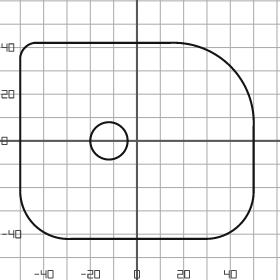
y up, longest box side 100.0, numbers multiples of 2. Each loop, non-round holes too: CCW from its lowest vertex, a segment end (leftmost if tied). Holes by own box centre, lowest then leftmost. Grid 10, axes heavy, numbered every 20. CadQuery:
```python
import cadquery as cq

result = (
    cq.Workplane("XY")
    .moveTo(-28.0, -42.0)
    .lineTo(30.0, -42.0)
    .threePointArc((44.0, -36.0), (50.0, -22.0))
    .lineTo(50.0, 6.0)
    .threePointArc((40.0, 32.0), (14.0, 42.0))
    .lineTo(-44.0, 42.0)
    .threePointArc((-48.0, 40.0), (-50.0, 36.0))
    .lineTo(-50.0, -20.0)
    .threePointArc((-44.0, -36.0), (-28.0, -42.0))
    .close()
    .moveTo(-12.0, 0.0)
    .circle(8.0)
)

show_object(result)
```